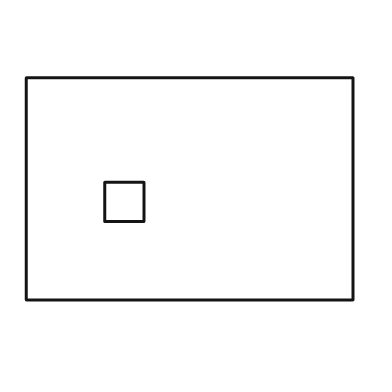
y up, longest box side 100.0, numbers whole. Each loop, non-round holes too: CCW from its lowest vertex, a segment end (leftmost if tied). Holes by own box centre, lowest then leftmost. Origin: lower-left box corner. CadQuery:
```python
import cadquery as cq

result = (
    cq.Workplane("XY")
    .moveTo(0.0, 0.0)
    .lineTo(100.0, 0.0)
    .lineTo(100.0, 68.0)
    .lineTo(0.0, 68.0)
    .close()
    .moveTo(24.0, 24.0)
    .lineTo(36.0, 24.0)
    .lineTo(36.0, 36.0)
    .lineTo(24.0, 36.0)
    .close()
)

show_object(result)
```